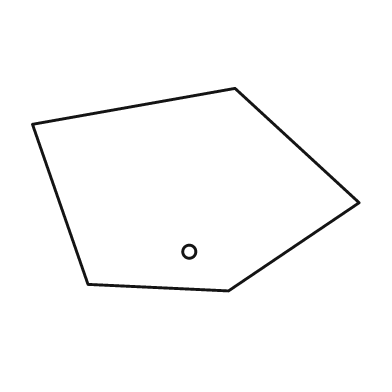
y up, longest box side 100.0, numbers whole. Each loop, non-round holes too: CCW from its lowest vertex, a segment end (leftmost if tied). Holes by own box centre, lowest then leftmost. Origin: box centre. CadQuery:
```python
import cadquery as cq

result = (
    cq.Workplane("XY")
    .moveTo(10.0, -31.0)
    .lineTo(50.0, -4.0)
    .lineTo(12.0, 31.0)
    .lineTo(-50.0, 20.0)
    .lineTo(-33.0, -29.0)
    .close()
    .moveTo(-2.0, -19.0)
    .circle(2.0)
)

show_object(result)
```